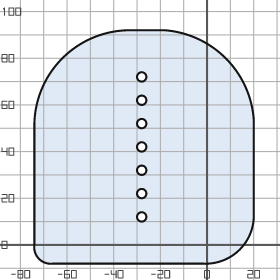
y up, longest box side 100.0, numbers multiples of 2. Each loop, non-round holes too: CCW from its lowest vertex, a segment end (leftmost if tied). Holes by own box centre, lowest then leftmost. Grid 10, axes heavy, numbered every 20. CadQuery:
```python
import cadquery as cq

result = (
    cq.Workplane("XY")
    .moveTo(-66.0, -8.0)
    .lineTo(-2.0, -8.0)
    .threePointArc((14.0, -2.0), (20.0, 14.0))
    .lineTo(20.0, 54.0)
    .threePointArc((8.0, 80.0), (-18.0, 92.0))
    .lineTo(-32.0, 92.0)
    .threePointArc((-62.0, 80.0), (-74.0, 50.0))
    .lineTo(-74.0, 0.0)
    .threePointArc((-72.0, -6.0), (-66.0, -8.0))
    .close()
    .moveTo(-28.0, 12.0)
    .circle(2.0)
    .moveTo(-28.0, 22.0)
    .circle(2.0)
    .moveTo(-28.0, 32.0)
    .circle(2.0)
    .moveTo(-28.0, 42.0)
    .circle(2.0)
    .moveTo(-28.0, 52.0)
    .circle(2.0)
    .moveTo(-28.0, 62.0)
    .circle(2.0)
    .moveTo(-28.0, 72.0)
    .circle(2.0)
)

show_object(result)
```